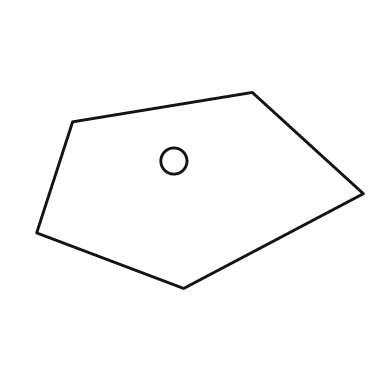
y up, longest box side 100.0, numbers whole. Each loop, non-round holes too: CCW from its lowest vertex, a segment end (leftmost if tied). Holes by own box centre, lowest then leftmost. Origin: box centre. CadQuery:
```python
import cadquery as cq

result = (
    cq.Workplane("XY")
    .moveTo(-5.0, -30.0)
    .lineTo(50.0, -1.0)
    .lineTo(16.0, 30.0)
    .lineTo(-39.0, 21.0)
    .lineTo(-50.0, -13.0)
    .close()
    .moveTo(-8.0, 9.0)
    .circle(4.0)
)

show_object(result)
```